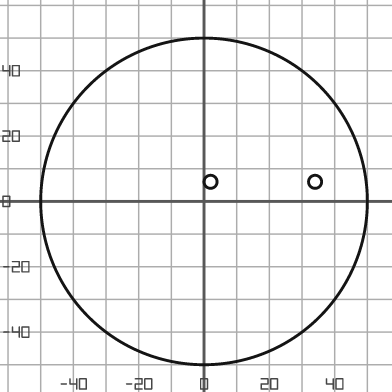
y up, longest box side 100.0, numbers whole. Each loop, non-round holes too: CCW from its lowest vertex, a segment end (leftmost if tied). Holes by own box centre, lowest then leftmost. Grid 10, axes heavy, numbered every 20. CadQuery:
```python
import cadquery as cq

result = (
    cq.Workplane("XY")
    .moveTo(0.0, 0.0)
    .circle(50.0)
    .moveTo(2.0, 6.0)
    .circle(2.0)
    .moveTo(34.0, 6.0)
    .circle(2.0)
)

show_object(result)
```